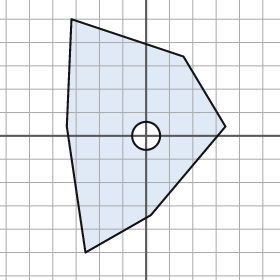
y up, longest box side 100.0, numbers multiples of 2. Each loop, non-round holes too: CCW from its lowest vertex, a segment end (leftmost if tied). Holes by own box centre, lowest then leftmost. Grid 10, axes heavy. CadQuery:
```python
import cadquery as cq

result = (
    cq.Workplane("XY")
    .moveTo(-26.0, -50.0)
    .lineTo(2.0, -34.0)
    .lineTo(34.0, 4.0)
    .lineTo(16.0, 34.0)
    .lineTo(-32.0, 50.0)
    .lineTo(-34.0, 4.0)
    .close()
    .moveTo(0.0, 0.0)
    .circle(6.0)
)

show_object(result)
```